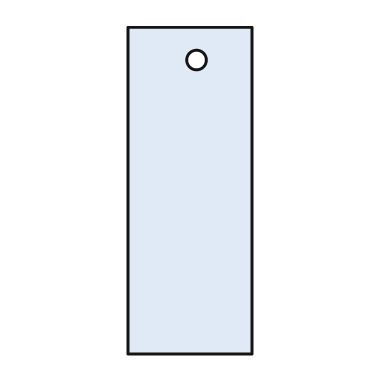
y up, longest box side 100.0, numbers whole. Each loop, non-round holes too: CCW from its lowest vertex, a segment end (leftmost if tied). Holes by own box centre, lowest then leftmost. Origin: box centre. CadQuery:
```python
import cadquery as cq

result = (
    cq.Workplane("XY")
    .moveTo(-19.0, -50.0)
    .lineTo(19.0, -50.0)
    .lineTo(19.0, 50.0)
    .lineTo(-19.0, 50.0)
    .close()
    .moveTo(2.0, 40.0)
    .circle(3.0)
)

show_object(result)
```